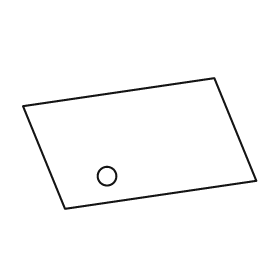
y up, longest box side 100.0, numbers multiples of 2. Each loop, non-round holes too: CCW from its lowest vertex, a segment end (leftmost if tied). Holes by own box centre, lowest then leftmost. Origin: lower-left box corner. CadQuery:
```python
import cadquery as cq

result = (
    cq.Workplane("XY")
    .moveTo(18.0, 0.0)
    .lineTo(100.0, 12.0)
    .lineTo(82.0, 56.0)
    .lineTo(0.0, 44.0)
    .close()
    .moveTo(36.0, 14.0)
    .circle(4.0)
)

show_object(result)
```